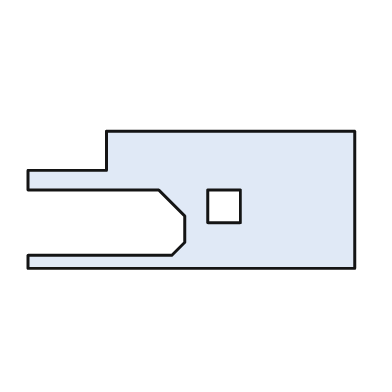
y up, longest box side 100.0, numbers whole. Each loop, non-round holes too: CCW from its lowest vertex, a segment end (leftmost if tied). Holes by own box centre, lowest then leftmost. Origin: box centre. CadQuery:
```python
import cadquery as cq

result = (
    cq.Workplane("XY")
    .moveTo(-50.0, -21.0)
    .lineTo(50.0, -21.0)
    .lineTo(50.0, 21.0)
    .lineTo(-26.0, 21.0)
    .lineTo(-26.0, 9.0)
    .lineTo(-50.0, 9.0)
    .lineTo(-50.0, 3.0)
    .lineTo(-10.0, 3.0)
    .lineTo(-2.0, -5.0)
    .lineTo(-2.0, -13.0)
    .lineTo(-6.0, -17.0)
    .lineTo(-50.0, -17.0)
    .close()
    .moveTo(5.0, -7.0)
    .lineTo(15.0, -7.0)
    .lineTo(15.0, 3.0)
    .lineTo(5.0, 3.0)
    .close()
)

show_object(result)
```